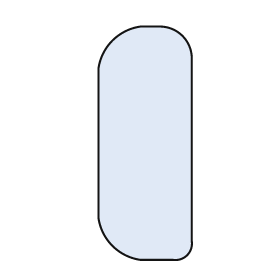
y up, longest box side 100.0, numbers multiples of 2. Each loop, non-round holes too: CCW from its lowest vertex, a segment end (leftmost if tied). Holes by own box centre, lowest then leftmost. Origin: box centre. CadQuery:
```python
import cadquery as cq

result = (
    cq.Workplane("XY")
    .moveTo(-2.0, -50.0)
    .lineTo(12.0, -50.0)
    .threePointArc((18.0, -48.0), (20.0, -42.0))
    .lineTo(20.0, 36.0)
    .threePointArc((16.0, 46.0), (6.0, 50.0))
    .lineTo(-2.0, 50.0)
    .threePointArc((-14.0, 44.0), (-20.0, 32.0))
    .lineTo(-20.0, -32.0)
    .threePointArc((-14.0, -44.0), (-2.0, -50.0))
    .close()
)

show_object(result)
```